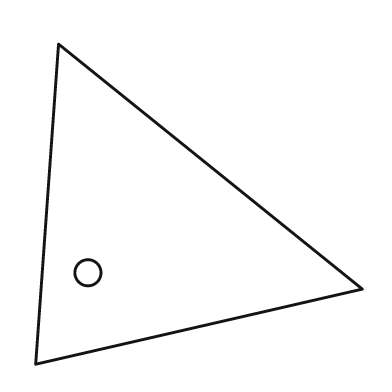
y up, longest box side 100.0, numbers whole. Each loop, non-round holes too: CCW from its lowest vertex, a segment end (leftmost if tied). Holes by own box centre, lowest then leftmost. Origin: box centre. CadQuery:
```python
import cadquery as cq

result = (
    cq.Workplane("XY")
    .moveTo(-50.0, -49.0)
    .lineTo(50.0, -26.0)
    .lineTo(-43.0, 49.0)
    .close()
    .moveTo(-34.0, -21.0)
    .circle(4.0)
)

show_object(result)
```